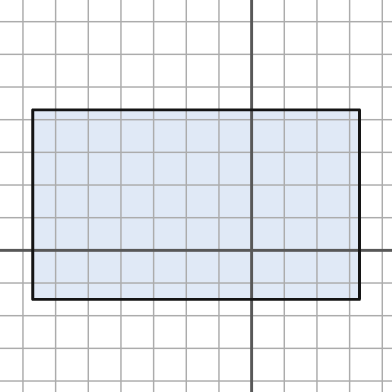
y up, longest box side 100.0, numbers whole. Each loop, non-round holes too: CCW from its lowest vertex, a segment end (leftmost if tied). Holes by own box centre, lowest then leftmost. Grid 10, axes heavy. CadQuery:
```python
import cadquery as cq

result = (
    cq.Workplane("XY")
    .moveTo(-67.0, -15.0)
    .lineTo(33.0, -15.0)
    .lineTo(33.0, 43.0)
    .lineTo(-67.0, 43.0)
    .close()
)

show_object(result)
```